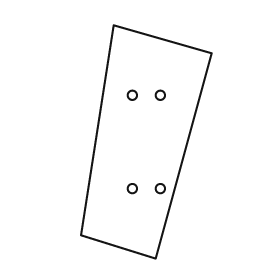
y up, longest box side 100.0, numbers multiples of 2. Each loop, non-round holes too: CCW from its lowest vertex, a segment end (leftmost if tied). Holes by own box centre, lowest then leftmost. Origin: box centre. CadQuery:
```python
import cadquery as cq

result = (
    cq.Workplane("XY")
    .moveTo(4.0, -50.0)
    .lineTo(28.0, 38.0)
    .lineTo(-14.0, 50.0)
    .lineTo(-28.0, -40.0)
    .close()
    .moveTo(-6.0, -20.0)
    .circle(2.0)
    .moveTo(6.0, -20.0)
    .circle(2.0)
    .moveTo(-6.0, 20.0)
    .circle(2.0)
    .moveTo(6.0, 20.0)
    .circle(2.0)
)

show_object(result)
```